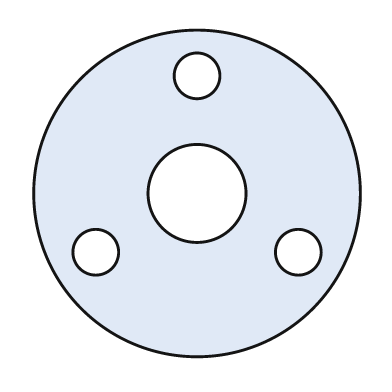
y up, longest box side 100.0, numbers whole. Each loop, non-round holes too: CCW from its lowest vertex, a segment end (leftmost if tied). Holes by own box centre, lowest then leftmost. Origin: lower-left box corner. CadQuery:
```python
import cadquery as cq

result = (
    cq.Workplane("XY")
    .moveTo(50.0, 50.0)
    .circle(50.0)
    .moveTo(19.0, 32.0)
    .circle(7.0)
    .moveTo(81.0, 32.0)
    .circle(7.0)
    .moveTo(50.0, 50.0)
    .circle(15.0)
    .moveTo(50.0, 86.0)
    .circle(7.0)
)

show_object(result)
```